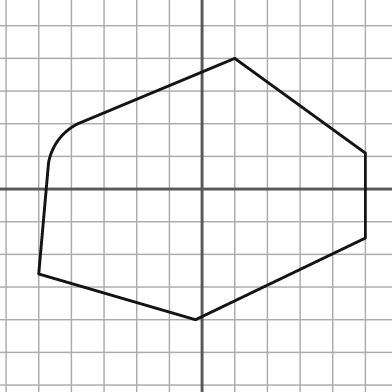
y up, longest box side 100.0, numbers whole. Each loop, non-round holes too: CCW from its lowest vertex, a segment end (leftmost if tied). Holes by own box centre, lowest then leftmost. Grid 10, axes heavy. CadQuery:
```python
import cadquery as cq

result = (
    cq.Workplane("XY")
    .moveTo(-2.0, -40.0)
    .lineTo(50.0, -15.0)
    .lineTo(50.0, 11.0)
    .lineTo(10.0, 40.0)
    .lineTo(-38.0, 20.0)
    .threePointArc((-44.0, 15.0), (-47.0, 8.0))
    .lineTo(-50.0, -26.0)
    .close()
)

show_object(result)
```